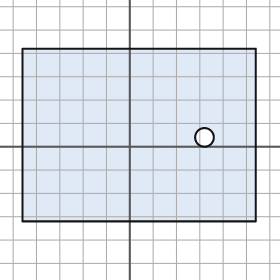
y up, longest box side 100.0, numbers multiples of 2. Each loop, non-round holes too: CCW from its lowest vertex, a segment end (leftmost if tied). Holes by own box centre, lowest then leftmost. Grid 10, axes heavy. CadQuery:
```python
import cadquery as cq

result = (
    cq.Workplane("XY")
    .moveTo(-46.0, -32.0)
    .lineTo(54.0, -32.0)
    .lineTo(54.0, 42.0)
    .lineTo(-46.0, 42.0)
    .close()
    .moveTo(32.0, 4.0)
    .circle(4.0)
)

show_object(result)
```